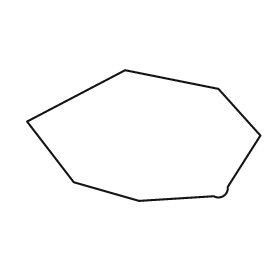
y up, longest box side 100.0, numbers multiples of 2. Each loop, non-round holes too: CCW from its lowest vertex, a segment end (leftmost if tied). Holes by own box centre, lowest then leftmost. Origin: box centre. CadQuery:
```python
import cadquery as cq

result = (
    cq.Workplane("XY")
    .moveTo(-2.0, -28.0)
    .lineTo(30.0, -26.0)
    .threePointArc((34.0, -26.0), (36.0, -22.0))
    .lineTo(50.0, 0.0)
    .lineTo(32.0, 20.0)
    .lineTo(-8.0, 28.0)
    .lineTo(-50.0, 6.0)
    .lineTo(-30.0, -20.0)
    .close()
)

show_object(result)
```